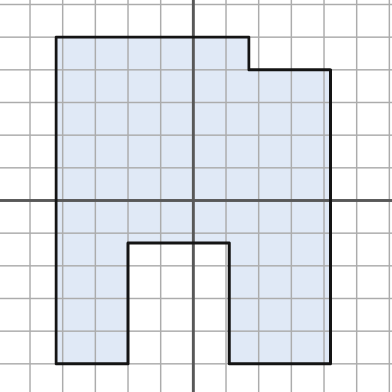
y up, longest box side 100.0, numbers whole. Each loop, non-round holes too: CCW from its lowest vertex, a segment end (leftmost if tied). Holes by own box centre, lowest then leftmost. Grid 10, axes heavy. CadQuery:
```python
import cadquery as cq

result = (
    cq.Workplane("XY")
    .moveTo(-42.0, -50.0)
    .lineTo(-20.0, -50.0)
    .lineTo(-20.0, -13.0)
    .lineTo(11.0, -13.0)
    .lineTo(11.0, -50.0)
    .lineTo(42.0, -50.0)
    .lineTo(42.0, 40.0)
    .lineTo(17.0, 40.0)
    .lineTo(17.0, 50.0)
    .lineTo(-42.0, 50.0)
    .close()
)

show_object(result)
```